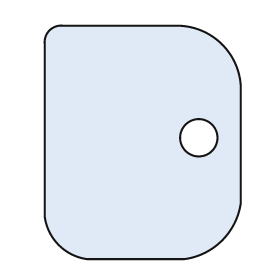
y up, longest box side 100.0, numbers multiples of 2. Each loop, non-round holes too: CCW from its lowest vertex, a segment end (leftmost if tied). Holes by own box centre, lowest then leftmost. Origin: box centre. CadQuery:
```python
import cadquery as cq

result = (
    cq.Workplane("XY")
    .moveTo(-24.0, -50.0)
    .lineTo(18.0, -50.0)
    .threePointArc((34.0, -42.0), (42.0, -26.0))
    .lineTo(42.0, 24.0)
    .threePointArc((34.0, 42.0), (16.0, 50.0))
    .lineTo(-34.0, 50.0)
    .threePointArc((-40.0, 48.0), (-42.0, 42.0))
    .lineTo(-42.0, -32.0)
    .threePointArc((-36.0, -44.0), (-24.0, -50.0))
    .close()
    .moveTo(24.0, 2.0)
    .circle(8.0)
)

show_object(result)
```